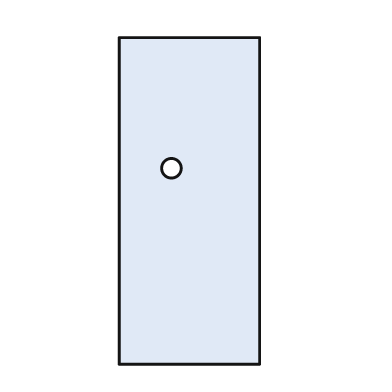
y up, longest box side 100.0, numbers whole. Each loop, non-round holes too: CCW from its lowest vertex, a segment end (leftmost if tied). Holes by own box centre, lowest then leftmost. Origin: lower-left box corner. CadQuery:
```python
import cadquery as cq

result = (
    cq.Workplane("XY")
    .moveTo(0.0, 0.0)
    .lineTo(43.0, 0.0)
    .lineTo(43.0, 100.0)
    .lineTo(0.0, 100.0)
    .close()
    .moveTo(16.0, 60.0)
    .circle(3.0)
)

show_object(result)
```